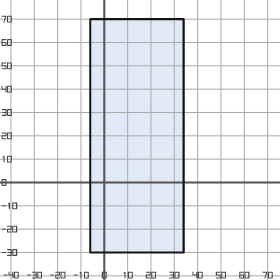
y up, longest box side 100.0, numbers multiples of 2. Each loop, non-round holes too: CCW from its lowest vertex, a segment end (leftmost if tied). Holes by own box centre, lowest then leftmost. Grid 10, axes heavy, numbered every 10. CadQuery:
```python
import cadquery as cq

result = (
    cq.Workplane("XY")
    .moveTo(-6.0, -30.0)
    .lineTo(34.0, -30.0)
    .lineTo(34.0, 70.0)
    .lineTo(-6.0, 70.0)
    .close()
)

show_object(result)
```